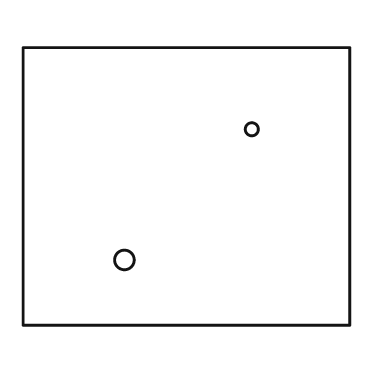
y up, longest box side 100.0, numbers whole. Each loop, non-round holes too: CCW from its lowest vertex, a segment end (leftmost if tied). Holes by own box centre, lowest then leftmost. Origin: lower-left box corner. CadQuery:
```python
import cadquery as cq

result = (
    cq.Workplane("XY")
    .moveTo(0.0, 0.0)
    .lineTo(100.0, 0.0)
    .lineTo(100.0, 85.0)
    .lineTo(0.0, 85.0)
    .close()
    .moveTo(31.0, 20.0)
    .circle(3.0)
    .moveTo(70.0, 60.0)
    .circle(2.0)
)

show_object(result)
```